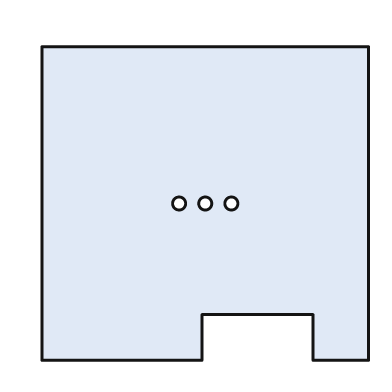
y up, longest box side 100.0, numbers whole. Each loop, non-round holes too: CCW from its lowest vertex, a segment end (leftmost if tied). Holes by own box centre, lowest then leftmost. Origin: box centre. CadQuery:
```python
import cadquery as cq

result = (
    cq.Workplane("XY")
    .moveTo(-50.0, -48.0)
    .lineTo(-1.0, -48.0)
    .lineTo(-1.0, -34.0)
    .lineTo(33.0, -34.0)
    .lineTo(33.0, -48.0)
    .lineTo(50.0, -48.0)
    .lineTo(50.0, 48.0)
    .lineTo(-50.0, 48.0)
    .close()
    .moveTo(-8.0, 0.0)
    .circle(2.0)
    .moveTo(0.0, 0.0)
    .circle(2.0)
    .moveTo(8.0, 0.0)
    .circle(2.0)
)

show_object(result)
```